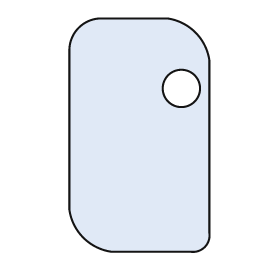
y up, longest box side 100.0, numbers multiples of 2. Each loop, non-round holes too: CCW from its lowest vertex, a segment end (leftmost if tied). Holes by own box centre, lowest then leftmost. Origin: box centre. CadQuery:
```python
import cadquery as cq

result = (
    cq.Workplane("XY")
    .moveTo(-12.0, -50.0)
    .lineTo(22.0, -50.0)
    .threePointArc((28.0, -48.0), (30.0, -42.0))
    .lineTo(30.0, 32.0)
    .threePointArc((24.0, 44.0), (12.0, 50.0))
    .lineTo(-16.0, 50.0)
    .threePointArc((-26.0, 46.0), (-30.0, 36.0))
    .lineTo(-30.0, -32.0)
    .threePointArc((-24.0, -44.0), (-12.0, -50.0))
    .close()
    .moveTo(18.0, 20.0)
    .circle(8.0)
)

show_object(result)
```